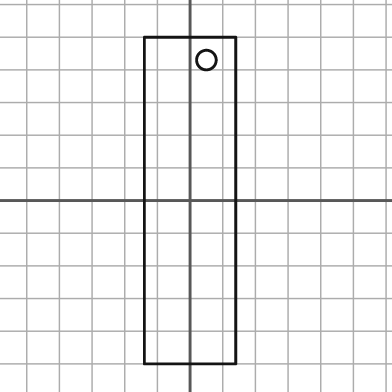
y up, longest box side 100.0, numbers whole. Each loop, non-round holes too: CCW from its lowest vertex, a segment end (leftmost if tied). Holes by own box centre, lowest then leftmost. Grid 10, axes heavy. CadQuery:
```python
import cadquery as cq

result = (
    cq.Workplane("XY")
    .moveTo(-14.0, -50.0)
    .lineTo(14.0, -50.0)
    .lineTo(14.0, 50.0)
    .lineTo(-14.0, 50.0)
    .close()
    .moveTo(5.0, 43.0)
    .circle(3.0)
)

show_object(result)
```